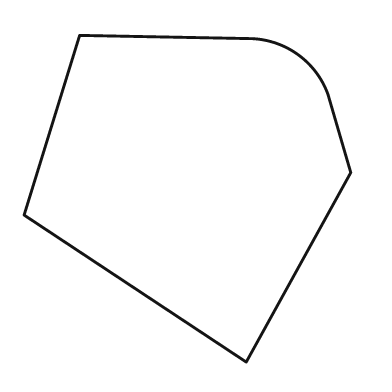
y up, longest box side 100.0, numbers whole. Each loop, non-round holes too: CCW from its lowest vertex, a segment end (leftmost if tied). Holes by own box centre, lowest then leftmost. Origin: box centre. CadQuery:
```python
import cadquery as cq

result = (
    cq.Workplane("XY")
    .moveTo(18.0, -50.0)
    .lineTo(50.0, 8.0)
    .lineTo(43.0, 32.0)
    .threePointArc((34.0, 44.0), (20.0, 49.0))
    .lineTo(-33.0, 50.0)
    .lineTo(-50.0, -5.0)
    .close()
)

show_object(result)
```